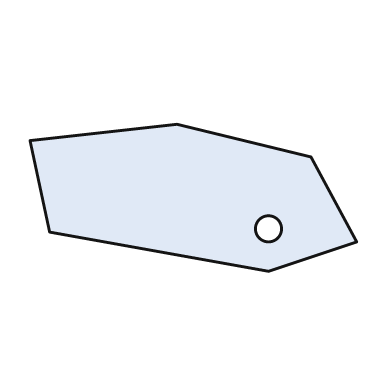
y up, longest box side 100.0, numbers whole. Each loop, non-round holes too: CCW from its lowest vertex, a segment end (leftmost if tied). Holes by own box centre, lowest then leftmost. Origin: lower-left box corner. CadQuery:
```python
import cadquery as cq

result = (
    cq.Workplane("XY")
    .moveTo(73.0, 0.0)
    .lineTo(100.0, 9.0)
    .lineTo(86.0, 35.0)
    .lineTo(45.0, 45.0)
    .lineTo(0.0, 40.0)
    .lineTo(6.0, 12.0)
    .close()
    .moveTo(73.0, 13.0)
    .circle(4.0)
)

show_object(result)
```